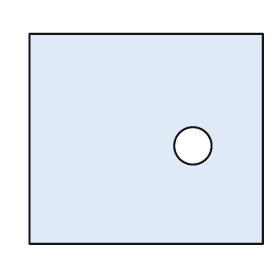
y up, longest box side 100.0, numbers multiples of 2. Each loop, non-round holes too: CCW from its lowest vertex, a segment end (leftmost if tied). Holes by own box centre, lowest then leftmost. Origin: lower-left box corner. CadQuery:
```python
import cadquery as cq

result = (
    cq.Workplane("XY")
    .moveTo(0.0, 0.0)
    .lineTo(100.0, 0.0)
    .lineTo(100.0, 90.0)
    .lineTo(0.0, 90.0)
    .close()
    .moveTo(70.0, 42.0)
    .circle(8.0)
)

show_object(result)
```